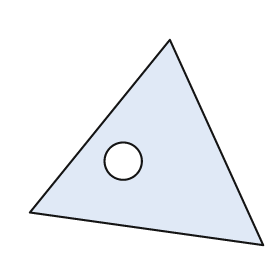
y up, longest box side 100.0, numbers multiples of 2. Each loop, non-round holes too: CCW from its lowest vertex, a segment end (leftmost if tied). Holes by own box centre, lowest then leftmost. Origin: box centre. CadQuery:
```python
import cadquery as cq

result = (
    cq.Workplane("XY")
    .moveTo(50.0, -44.0)
    .lineTo(10.0, 44.0)
    .lineTo(-50.0, -30.0)
    .close()
    .moveTo(-10.0, -8.0)
    .circle(8.0)
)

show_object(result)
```